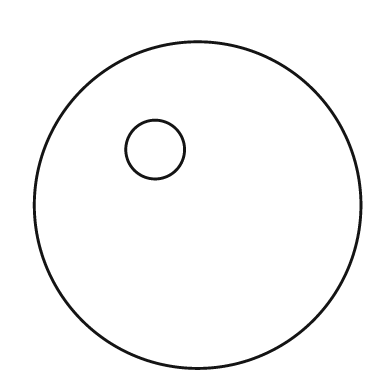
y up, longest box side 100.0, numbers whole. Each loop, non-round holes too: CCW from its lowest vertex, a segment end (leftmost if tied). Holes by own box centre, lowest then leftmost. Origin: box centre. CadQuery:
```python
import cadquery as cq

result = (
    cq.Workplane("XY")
    .moveTo(0.0, 0.0)
    .circle(50.0)
    .moveTo(-13.0, 17.0)
    .circle(9.0)
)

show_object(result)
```